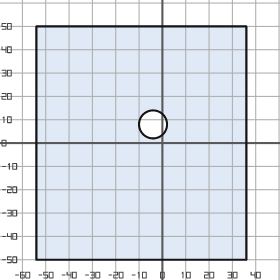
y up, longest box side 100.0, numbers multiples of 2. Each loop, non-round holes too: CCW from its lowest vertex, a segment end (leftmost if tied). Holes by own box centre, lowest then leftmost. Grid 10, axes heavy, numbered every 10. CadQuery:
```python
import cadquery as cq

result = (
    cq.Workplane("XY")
    .moveTo(-54.0, -50.0)
    .lineTo(36.0, -50.0)
    .lineTo(36.0, 50.0)
    .lineTo(-54.0, 50.0)
    .close()
    .moveTo(-4.0, 8.0)
    .circle(6.0)
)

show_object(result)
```